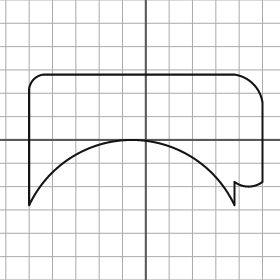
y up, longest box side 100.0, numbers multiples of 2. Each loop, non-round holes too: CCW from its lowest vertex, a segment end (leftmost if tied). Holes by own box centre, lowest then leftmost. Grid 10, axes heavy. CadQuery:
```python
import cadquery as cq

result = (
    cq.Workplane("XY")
    .moveTo(-50.0, -28.0)
    .threePointArc((-6.0, 0.0), (38.0, -28.0))
    .lineTo(38.0, -18.0)
    .threePointArc((44.0, -20.0), (50.0, -18.0))
    .lineTo(50.0, 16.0)
    .threePointArc((46.0, 24.0), (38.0, 28.0))
    .lineTo(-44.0, 28.0)
    .threePointArc((-48.0, 26.0), (-50.0, 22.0))
    .close()
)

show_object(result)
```